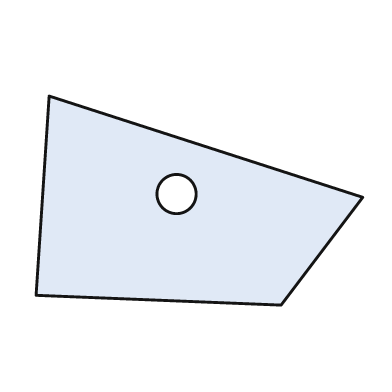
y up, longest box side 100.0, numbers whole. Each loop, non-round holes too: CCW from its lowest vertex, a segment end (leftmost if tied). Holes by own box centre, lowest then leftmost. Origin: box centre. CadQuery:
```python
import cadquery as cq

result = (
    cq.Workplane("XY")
    .moveTo(25.0, -32.0)
    .lineTo(50.0, 1.0)
    .lineTo(-46.0, 32.0)
    .lineTo(-50.0, -29.0)
    .close()
    .moveTo(-7.0, 2.0)
    .circle(6.0)
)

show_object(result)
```